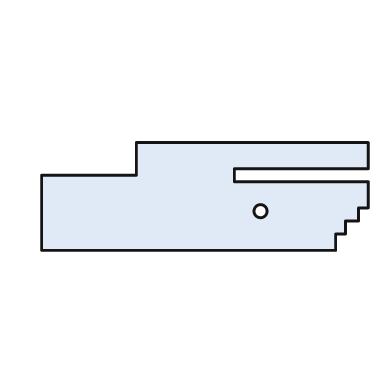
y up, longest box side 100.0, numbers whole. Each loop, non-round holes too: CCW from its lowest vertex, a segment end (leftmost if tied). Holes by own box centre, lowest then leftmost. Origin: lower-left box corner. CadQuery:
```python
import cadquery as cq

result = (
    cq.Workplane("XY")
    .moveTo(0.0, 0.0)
    .lineTo(90.0, 0.0)
    .lineTo(90.0, 5.0)
    .lineTo(93.0, 5.0)
    .lineTo(93.0, 9.0)
    .lineTo(97.0, 9.0)
    .lineTo(97.0, 13.0)
    .lineTo(100.0, 13.0)
    .lineTo(100.0, 21.0)
    .lineTo(59.0, 21.0)
    .lineTo(59.0, 25.0)
    .lineTo(100.0, 25.0)
    .lineTo(100.0, 33.0)
    .lineTo(29.0, 33.0)
    .lineTo(29.0, 23.0)
    .lineTo(0.0, 23.0)
    .close()
    .moveTo(67.0, 12.0)
    .circle(2.0)
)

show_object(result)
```